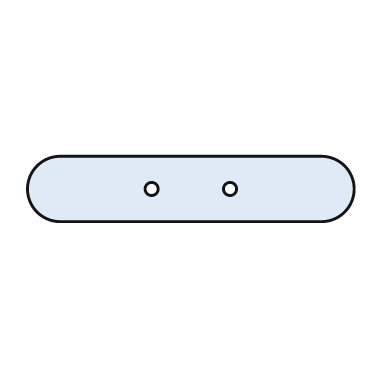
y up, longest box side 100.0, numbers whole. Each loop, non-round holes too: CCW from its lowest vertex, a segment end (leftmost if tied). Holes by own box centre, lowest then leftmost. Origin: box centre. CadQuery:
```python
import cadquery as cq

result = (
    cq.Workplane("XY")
    .moveTo(-40.0, -10.0)
    .lineTo(40.0, -10.0)
    .threePointArc((50.0, 0.0), (40.0, 10.0))
    .lineTo(-40.0, 10.0)
    .threePointArc((-50.0, 0.0), (-40.0, -10.0))
    .close()
    .moveTo(-12.0, 0.0)
    .circle(2.0)
    .moveTo(12.0, 0.0)
    .circle(2.0)
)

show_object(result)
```